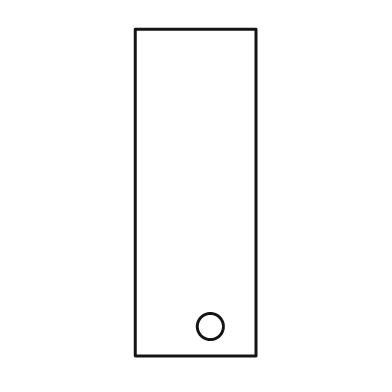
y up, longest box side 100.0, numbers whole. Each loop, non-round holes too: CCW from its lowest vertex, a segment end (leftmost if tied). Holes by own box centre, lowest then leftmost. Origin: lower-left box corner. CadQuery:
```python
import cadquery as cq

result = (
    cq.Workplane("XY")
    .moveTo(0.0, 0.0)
    .lineTo(37.0, 0.0)
    .lineTo(37.0, 100.0)
    .lineTo(0.0, 100.0)
    .close()
    .moveTo(23.0, 9.0)
    .circle(4.0)
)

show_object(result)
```